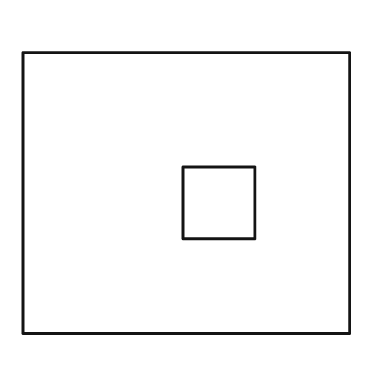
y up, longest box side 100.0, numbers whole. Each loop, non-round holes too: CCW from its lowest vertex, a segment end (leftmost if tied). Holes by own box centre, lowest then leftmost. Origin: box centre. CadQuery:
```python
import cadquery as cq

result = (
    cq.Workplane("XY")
    .moveTo(-50.0, -43.0)
    .lineTo(50.0, -43.0)
    .lineTo(50.0, 43.0)
    .lineTo(-50.0, 43.0)
    .close()
    .moveTo(-1.0, -14.0)
    .lineTo(21.0, -14.0)
    .lineTo(21.0, 8.0)
    .lineTo(-1.0, 8.0)
    .close()
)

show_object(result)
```